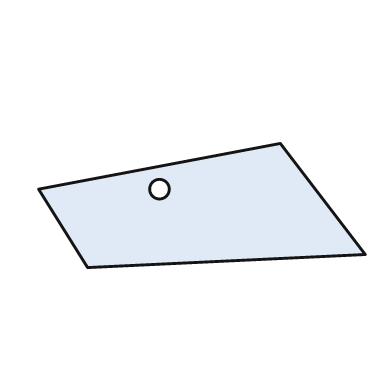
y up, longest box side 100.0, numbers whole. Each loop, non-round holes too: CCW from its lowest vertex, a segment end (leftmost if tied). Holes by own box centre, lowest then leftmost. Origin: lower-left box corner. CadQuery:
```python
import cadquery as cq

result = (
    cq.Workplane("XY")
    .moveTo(15.0, 0.0)
    .lineTo(100.0, 4.0)
    .lineTo(74.0, 38.0)
    .lineTo(0.0, 24.0)
    .close()
    .moveTo(37.0, 24.0)
    .circle(3.0)
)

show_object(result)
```